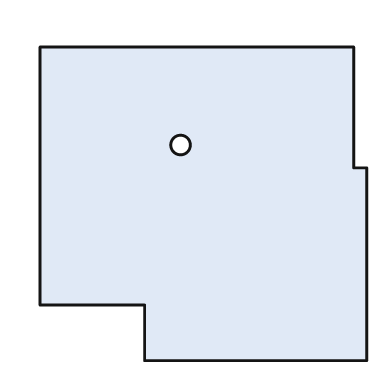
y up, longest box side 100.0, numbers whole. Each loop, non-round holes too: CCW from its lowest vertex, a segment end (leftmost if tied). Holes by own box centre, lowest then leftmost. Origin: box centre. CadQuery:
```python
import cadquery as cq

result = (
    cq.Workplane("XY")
    .moveTo(-18.0, -48.0)
    .lineTo(50.0, -48.0)
    .lineTo(50.0, 11.0)
    .lineTo(46.0, 11.0)
    .lineTo(46.0, 48.0)
    .lineTo(-50.0, 48.0)
    .lineTo(-50.0, -31.0)
    .lineTo(-18.0, -31.0)
    .close()
    .moveTo(-7.0, 18.0)
    .circle(3.0)
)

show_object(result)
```